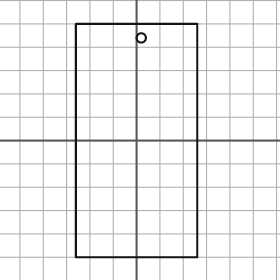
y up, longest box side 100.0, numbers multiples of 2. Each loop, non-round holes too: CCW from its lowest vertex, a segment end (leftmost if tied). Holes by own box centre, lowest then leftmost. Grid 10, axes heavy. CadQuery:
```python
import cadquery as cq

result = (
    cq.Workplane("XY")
    .moveTo(-26.0, -50.0)
    .lineTo(26.0, -50.0)
    .lineTo(26.0, 50.0)
    .lineTo(-26.0, 50.0)
    .close()
    .moveTo(2.0, 44.0)
    .circle(2.0)
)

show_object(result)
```